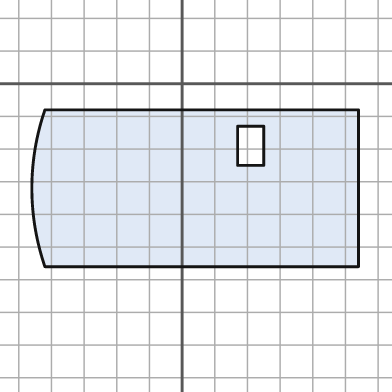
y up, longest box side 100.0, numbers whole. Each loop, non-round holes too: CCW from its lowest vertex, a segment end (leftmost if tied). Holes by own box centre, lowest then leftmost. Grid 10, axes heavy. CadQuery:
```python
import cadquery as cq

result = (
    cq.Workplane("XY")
    .moveTo(-42.0, -56.0)
    .lineTo(54.0, -56.0)
    .lineTo(54.0, -8.0)
    .lineTo(-42.0, -8.0)
    .threePointArc((-46.0, -32.0), (-42.0, -56.0))
    .close()
    .moveTo(17.0, -25.0)
    .lineTo(25.0, -25.0)
    .lineTo(25.0, -13.0)
    .lineTo(17.0, -13.0)
    .close()
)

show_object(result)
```